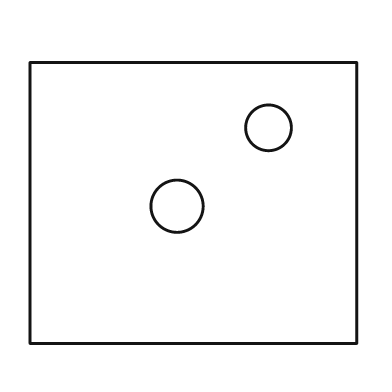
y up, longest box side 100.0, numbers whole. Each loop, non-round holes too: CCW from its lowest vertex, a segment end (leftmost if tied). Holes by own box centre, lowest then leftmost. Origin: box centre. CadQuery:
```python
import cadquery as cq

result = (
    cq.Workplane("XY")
    .moveTo(-50.0, -43.0)
    .lineTo(50.0, -43.0)
    .lineTo(50.0, 43.0)
    .lineTo(-50.0, 43.0)
    .close()
    .moveTo(-5.0, -1.0)
    .circle(8.0)
    .moveTo(23.0, 23.0)
    .circle(7.0)
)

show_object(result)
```